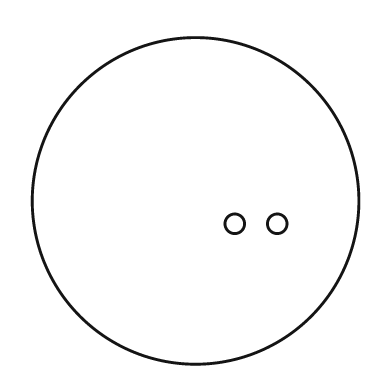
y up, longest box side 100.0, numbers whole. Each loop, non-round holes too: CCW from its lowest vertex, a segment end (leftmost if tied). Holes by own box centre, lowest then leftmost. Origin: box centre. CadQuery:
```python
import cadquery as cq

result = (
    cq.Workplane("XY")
    .moveTo(0.0, 0.0)
    .circle(50.0)
    .moveTo(12.0, -7.0)
    .circle(3.0)
    .moveTo(25.0, -7.0)
    .circle(3.0)
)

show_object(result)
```